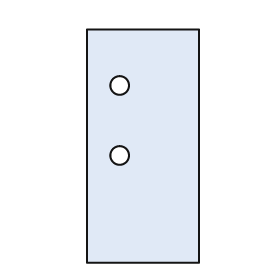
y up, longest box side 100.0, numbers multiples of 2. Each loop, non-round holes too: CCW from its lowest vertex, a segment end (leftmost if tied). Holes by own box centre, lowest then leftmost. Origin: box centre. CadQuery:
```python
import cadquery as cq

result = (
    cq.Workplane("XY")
    .moveTo(-24.0, -50.0)
    .lineTo(24.0, -50.0)
    .lineTo(24.0, 50.0)
    .lineTo(-24.0, 50.0)
    .close()
    .moveTo(-10.0, -4.0)
    .circle(4.0)
    .moveTo(-10.0, 26.0)
    .circle(4.0)
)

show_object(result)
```